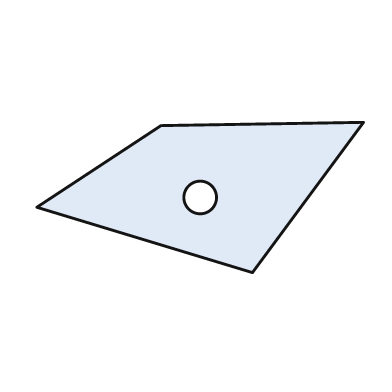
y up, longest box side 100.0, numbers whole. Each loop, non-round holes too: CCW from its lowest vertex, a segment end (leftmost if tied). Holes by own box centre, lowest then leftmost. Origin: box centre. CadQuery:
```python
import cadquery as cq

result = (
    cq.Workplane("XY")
    .moveTo(16.0, -23.0)
    .lineTo(50.0, 23.0)
    .lineTo(-12.0, 22.0)
    .lineTo(-50.0, -3.0)
    .close()
    .moveTo(0.0, 0.0)
    .circle(5.0)
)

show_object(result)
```